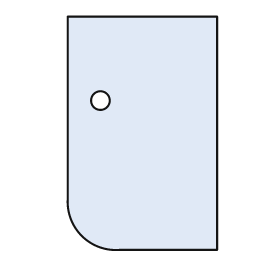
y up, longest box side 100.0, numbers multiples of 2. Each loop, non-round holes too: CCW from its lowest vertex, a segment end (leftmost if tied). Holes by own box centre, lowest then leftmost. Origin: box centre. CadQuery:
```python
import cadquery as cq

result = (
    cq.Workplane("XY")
    .moveTo(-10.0, -50.0)
    .lineTo(32.0, -50.0)
    .lineTo(32.0, 50.0)
    .lineTo(-32.0, 50.0)
    .lineTo(-32.0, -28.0)
    .threePointArc((-26.0, -44.0), (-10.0, -50.0))
    .close()
    .moveTo(-18.0, 14.0)
    .circle(4.0)
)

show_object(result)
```